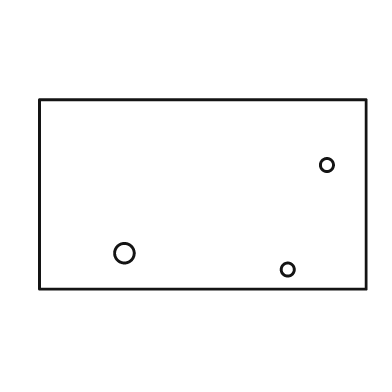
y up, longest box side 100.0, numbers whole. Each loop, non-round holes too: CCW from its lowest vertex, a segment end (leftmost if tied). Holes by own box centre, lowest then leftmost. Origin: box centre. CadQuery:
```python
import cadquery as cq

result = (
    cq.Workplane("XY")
    .moveTo(-50.0, -29.0)
    .lineTo(50.0, -29.0)
    .lineTo(50.0, 29.0)
    .lineTo(-50.0, 29.0)
    .close()
    .moveTo(26.0, -23.0)
    .circle(2.0)
    .moveTo(-24.0, -18.0)
    .circle(3.0)
    .moveTo(38.0, 9.0)
    .circle(2.0)
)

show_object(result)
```